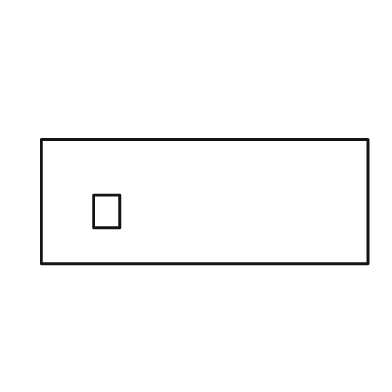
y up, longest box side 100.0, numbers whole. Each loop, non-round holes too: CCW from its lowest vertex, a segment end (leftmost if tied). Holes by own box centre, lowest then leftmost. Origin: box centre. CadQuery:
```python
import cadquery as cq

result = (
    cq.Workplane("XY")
    .moveTo(-50.0, -19.0)
    .lineTo(50.0, -19.0)
    .lineTo(50.0, 19.0)
    .lineTo(-50.0, 19.0)
    .close()
    .moveTo(-34.0, -8.0)
    .lineTo(-26.0, -8.0)
    .lineTo(-26.0, 2.0)
    .lineTo(-34.0, 2.0)
    .close()
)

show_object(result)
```